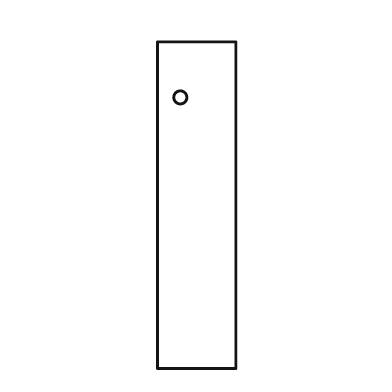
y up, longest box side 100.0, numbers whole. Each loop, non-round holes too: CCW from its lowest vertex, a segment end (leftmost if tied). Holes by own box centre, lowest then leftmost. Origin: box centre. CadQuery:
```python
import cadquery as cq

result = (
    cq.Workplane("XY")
    .moveTo(-12.0, -50.0)
    .lineTo(12.0, -50.0)
    .lineTo(12.0, 50.0)
    .lineTo(-12.0, 50.0)
    .close()
    .moveTo(-5.0, 33.0)
    .circle(2.0)
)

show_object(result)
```